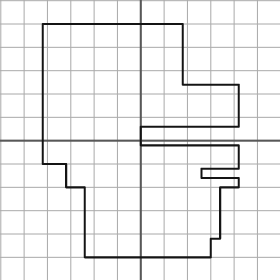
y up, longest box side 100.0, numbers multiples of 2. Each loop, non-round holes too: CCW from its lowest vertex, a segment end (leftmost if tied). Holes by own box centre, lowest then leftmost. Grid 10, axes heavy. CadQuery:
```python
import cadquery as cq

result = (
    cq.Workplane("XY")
    .moveTo(-24.0, -50.0)
    .lineTo(30.0, -50.0)
    .lineTo(30.0, -42.0)
    .lineTo(34.0, -42.0)
    .lineTo(34.0, -20.0)
    .lineTo(42.0, -20.0)
    .lineTo(42.0, -16.0)
    .lineTo(26.0, -16.0)
    .lineTo(26.0, -12.0)
    .lineTo(42.0, -12.0)
    .lineTo(42.0, -2.0)
    .lineTo(0.0, -2.0)
    .lineTo(0.0, 6.0)
    .lineTo(42.0, 6.0)
    .lineTo(42.0, 24.0)
    .lineTo(18.0, 24.0)
    .lineTo(18.0, 50.0)
    .lineTo(-42.0, 50.0)
    .lineTo(-42.0, -10.0)
    .lineTo(-32.0, -10.0)
    .lineTo(-32.0, -20.0)
    .lineTo(-24.0, -20.0)
    .close()
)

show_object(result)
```